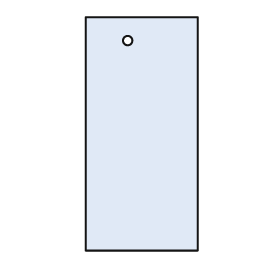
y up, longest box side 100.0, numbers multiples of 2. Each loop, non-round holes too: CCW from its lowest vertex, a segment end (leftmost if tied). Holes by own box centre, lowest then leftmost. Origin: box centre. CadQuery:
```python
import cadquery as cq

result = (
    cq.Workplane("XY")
    .moveTo(-24.0, -50.0)
    .lineTo(24.0, -50.0)
    .lineTo(24.0, 50.0)
    .lineTo(-24.0, 50.0)
    .close()
    .moveTo(-6.0, 40.0)
    .circle(2.0)
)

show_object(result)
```